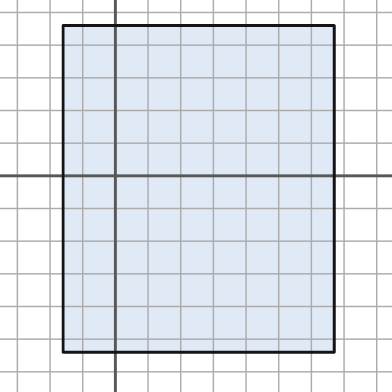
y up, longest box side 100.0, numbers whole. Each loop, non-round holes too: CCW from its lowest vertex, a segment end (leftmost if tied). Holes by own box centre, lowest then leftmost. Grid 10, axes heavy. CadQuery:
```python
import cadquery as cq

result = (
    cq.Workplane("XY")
    .moveTo(-16.0, -54.0)
    .lineTo(67.0, -54.0)
    .lineTo(67.0, 46.0)
    .lineTo(-16.0, 46.0)
    .close()
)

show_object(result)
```